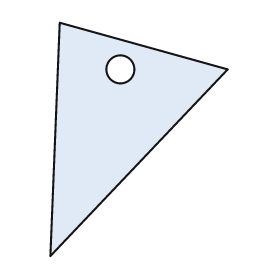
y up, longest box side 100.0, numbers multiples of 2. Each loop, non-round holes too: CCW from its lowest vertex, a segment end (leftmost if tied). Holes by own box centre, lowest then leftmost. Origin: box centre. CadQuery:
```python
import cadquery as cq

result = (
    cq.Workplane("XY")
    .moveTo(-38.0, -50.0)
    .lineTo(38.0, 30.0)
    .lineTo(-34.0, 50.0)
    .close()
    .moveTo(-8.0, 30.0)
    .circle(6.0)
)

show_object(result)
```